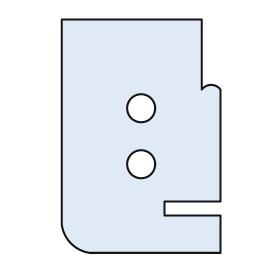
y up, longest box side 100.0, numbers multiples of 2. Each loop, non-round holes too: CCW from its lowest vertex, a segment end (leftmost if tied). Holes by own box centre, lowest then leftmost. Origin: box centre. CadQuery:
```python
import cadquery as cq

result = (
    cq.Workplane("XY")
    .moveTo(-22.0, -50.0)
    .lineTo(34.0, -50.0)
    .lineTo(34.0, -34.0)
    .lineTo(10.0, -34.0)
    .lineTo(10.0, -28.0)
    .lineTo(34.0, -28.0)
    .lineTo(34.0, 20.0)
    .threePointArc((30.0, 22.0), (26.0, 20.0))
    .lineTo(26.0, 50.0)
    .lineTo(-34.0, 50.0)
    .lineTo(-34.0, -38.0)
    .threePointArc((-30.0, -46.0), (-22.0, -50.0))
    .close()
    .moveTo(0.0, -12.0)
    .circle(6.0)
    .moveTo(0.0, 12.0)
    .circle(6.0)
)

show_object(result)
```